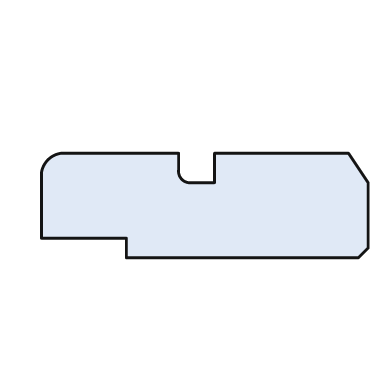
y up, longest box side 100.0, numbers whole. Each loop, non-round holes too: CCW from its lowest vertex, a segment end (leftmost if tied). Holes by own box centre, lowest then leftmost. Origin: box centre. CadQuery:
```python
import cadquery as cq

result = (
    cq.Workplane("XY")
    .moveTo(-24.0, -16.0)
    .lineTo(47.0, -16.0)
    .lineTo(50.0, -13.0)
    .lineTo(50.0, 7.0)
    .lineTo(44.0, 16.0)
    .lineTo(3.0, 16.0)
    .lineTo(3.0, 7.0)
    .lineTo(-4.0, 7.0)
    .threePointArc((-7.0, 8.0), (-8.0, 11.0))
    .lineTo(-8.0, 16.0)
    .lineTo(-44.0, 16.0)
    .threePointArc((-48.0, 14.0), (-50.0, 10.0))
    .lineTo(-50.0, -10.0)
    .lineTo(-24.0, -10.0)
    .close()
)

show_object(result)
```